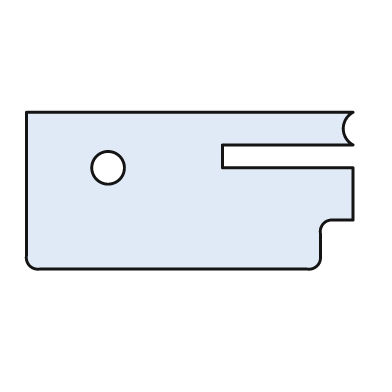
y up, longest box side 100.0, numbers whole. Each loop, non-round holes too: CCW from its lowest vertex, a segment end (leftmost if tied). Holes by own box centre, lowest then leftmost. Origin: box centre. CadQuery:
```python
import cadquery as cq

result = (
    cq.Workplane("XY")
    .moveTo(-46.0, -24.0)
    .lineTo(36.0, -24.0)
    .threePointArc((39.0, -23.0), (40.0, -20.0))
    .lineTo(40.0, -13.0)
    .threePointArc((41.0, -10.0), (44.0, -9.0))
    .lineTo(50.0, -9.0)
    .lineTo(50.0, 7.0)
    .lineTo(10.0, 7.0)
    .lineTo(10.0, 14.0)
    .lineTo(50.0, 14.0)
    .threePointArc((47.0, 19.0), (50.0, 24.0))
    .lineTo(-50.0, 24.0)
    .lineTo(-50.0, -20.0)
    .threePointArc((-49.0, -23.0), (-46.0, -24.0))
    .close()
    .moveTo(-25.0, 7.0)
    .circle(5.0)
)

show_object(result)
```